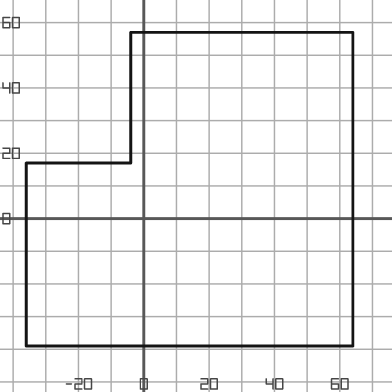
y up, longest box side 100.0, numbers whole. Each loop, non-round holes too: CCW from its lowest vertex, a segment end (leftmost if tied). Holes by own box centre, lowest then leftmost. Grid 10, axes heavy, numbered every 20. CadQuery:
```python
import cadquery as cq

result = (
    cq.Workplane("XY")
    .moveTo(-36.0, -39.0)
    .lineTo(64.0, -39.0)
    .lineTo(64.0, 57.0)
    .lineTo(-4.0, 57.0)
    .lineTo(-4.0, 17.0)
    .lineTo(-36.0, 17.0)
    .close()
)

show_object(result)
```